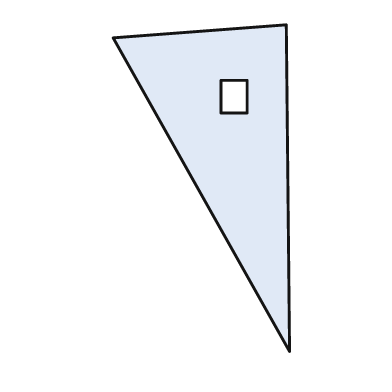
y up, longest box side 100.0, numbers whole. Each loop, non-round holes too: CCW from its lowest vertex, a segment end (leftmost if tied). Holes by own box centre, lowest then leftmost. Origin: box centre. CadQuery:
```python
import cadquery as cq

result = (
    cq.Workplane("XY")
    .moveTo(27.0, -50.0)
    .lineTo(26.0, 50.0)
    .lineTo(-27.0, 46.0)
    .close()
    .moveTo(6.0, 23.0)
    .lineTo(14.0, 23.0)
    .lineTo(14.0, 33.0)
    .lineTo(6.0, 33.0)
    .close()
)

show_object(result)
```